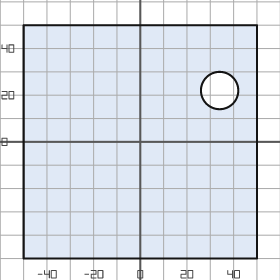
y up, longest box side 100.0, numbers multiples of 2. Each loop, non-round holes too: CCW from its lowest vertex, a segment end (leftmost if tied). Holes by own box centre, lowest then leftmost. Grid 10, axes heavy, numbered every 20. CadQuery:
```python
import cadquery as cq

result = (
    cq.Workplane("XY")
    .moveTo(-50.0, -50.0)
    .lineTo(50.0, -50.0)
    .lineTo(50.0, 50.0)
    .lineTo(-50.0, 50.0)
    .close()
    .moveTo(34.0, 22.0)
    .circle(8.0)
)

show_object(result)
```